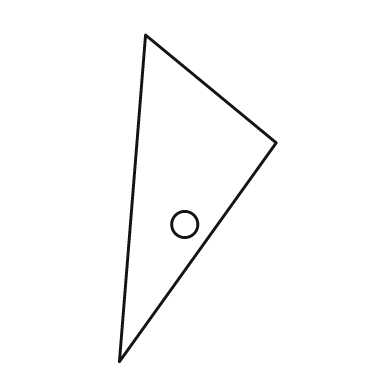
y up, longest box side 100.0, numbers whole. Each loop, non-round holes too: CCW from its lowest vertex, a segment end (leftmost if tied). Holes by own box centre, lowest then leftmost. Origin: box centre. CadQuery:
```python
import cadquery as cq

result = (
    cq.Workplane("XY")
    .moveTo(-24.0, -50.0)
    .lineTo(24.0, 17.0)
    .lineTo(-16.0, 50.0)
    .close()
    .moveTo(-4.0, -8.0)
    .circle(4.0)
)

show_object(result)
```